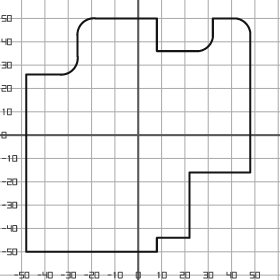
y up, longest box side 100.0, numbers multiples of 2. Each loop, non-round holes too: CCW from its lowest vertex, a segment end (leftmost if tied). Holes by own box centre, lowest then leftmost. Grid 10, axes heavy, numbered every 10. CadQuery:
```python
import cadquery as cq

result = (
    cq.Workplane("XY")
    .moveTo(-48.0, -50.0)
    .lineTo(8.0, -50.0)
    .lineTo(8.0, -44.0)
    .lineTo(22.0, -44.0)
    .lineTo(22.0, -16.0)
    .lineTo(48.0, -16.0)
    .lineTo(48.0, 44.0)
    .threePointArc((46.0, 48.0), (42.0, 50.0))
    .lineTo(32.0, 50.0)
    .lineTo(32.0, 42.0)
    .threePointArc((30.0, 38.0), (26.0, 36.0))
    .lineTo(8.0, 36.0)
    .lineTo(8.0, 50.0)
    .lineTo(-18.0, 50.0)
    .threePointArc((-24.0, 48.0), (-26.0, 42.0))
    .lineTo(-26.0, 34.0)
    .threePointArc((-28.0, 28.0), (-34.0, 26.0))
    .lineTo(-48.0, 26.0)
    .close()
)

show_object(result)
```